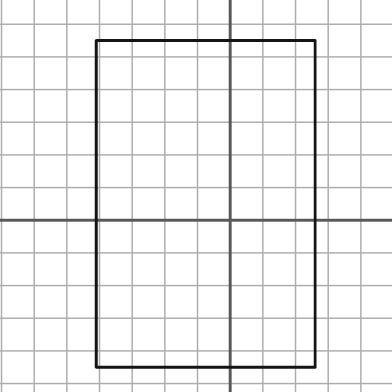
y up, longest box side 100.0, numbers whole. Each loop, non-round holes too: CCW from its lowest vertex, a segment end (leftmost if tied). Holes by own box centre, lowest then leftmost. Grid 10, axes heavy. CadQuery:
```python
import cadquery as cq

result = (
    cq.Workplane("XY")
    .moveTo(-41.0, -45.0)
    .lineTo(26.0, -45.0)
    .lineTo(26.0, 55.0)
    .lineTo(-41.0, 55.0)
    .close()
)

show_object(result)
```